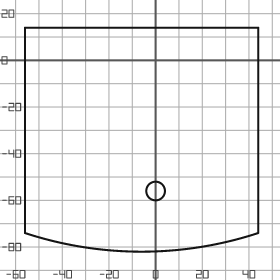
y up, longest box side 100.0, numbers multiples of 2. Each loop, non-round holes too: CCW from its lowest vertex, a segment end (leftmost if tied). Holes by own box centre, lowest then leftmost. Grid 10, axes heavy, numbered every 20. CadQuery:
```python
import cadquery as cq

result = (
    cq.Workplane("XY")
    .moveTo(-56.0, -74.0)
    .threePointArc((-6.0, -82.0), (44.0, -74.0))
    .lineTo(44.0, 14.0)
    .lineTo(-56.0, 14.0)
    .close()
    .moveTo(0.0, -56.0)
    .circle(4.0)
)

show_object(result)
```